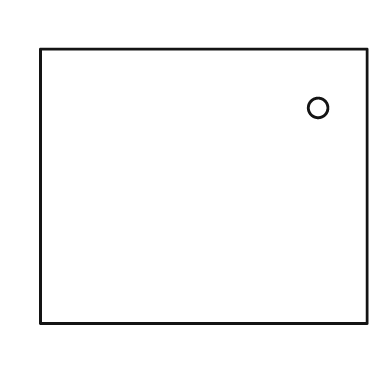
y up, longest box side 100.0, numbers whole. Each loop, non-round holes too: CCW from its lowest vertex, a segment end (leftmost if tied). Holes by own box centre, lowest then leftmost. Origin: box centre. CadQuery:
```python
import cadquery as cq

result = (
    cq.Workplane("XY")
    .moveTo(-50.0, -42.0)
    .lineTo(50.0, -42.0)
    .lineTo(50.0, 42.0)
    .lineTo(-50.0, 42.0)
    .close()
    .moveTo(35.0, 24.0)
    .circle(3.0)
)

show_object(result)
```